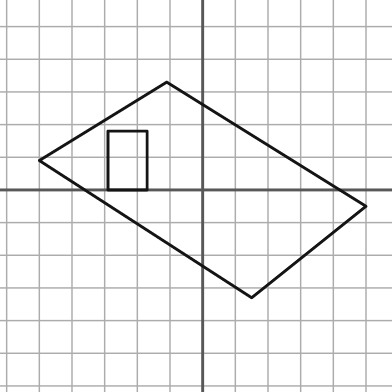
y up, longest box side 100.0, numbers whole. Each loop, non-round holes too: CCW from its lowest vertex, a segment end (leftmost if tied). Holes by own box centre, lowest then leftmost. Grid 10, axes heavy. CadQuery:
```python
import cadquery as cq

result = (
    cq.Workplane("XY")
    .moveTo(15.0, -33.0)
    .lineTo(50.0, -5.0)
    .lineTo(-11.0, 33.0)
    .lineTo(-50.0, 9.0)
    .close()
    .moveTo(-29.0, 0.0)
    .lineTo(-17.0, 0.0)
    .lineTo(-17.0, 18.0)
    .lineTo(-29.0, 18.0)
    .close()
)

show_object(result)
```